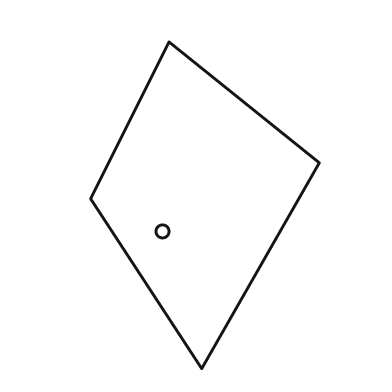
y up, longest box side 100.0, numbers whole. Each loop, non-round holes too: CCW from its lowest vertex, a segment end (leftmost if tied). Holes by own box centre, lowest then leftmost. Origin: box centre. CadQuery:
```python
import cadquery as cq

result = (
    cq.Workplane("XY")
    .moveTo(-1.0, -50.0)
    .lineTo(35.0, 13.0)
    .lineTo(-11.0, 50.0)
    .lineTo(-35.0, 2.0)
    .close()
    .moveTo(-13.0, -8.0)
    .circle(2.0)
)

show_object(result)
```